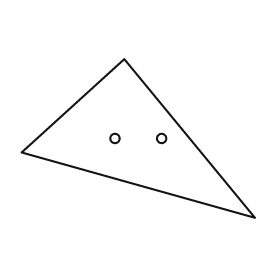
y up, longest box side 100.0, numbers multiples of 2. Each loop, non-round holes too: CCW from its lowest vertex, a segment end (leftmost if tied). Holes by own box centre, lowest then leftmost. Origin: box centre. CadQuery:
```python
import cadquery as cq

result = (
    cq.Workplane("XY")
    .moveTo(50.0, -34.0)
    .lineTo(-6.0, 34.0)
    .lineTo(-50.0, -6.0)
    .close()
    .moveTo(-10.0, 0.0)
    .circle(2.0)
    .moveTo(10.0, 0.0)
    .circle(2.0)
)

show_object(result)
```